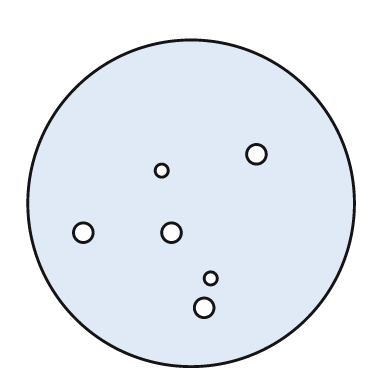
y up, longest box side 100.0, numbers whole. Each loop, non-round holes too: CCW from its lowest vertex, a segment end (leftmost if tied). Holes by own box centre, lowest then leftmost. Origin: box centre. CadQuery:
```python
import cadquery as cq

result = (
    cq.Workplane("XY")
    .moveTo(0.0, 0.0)
    .circle(50.0)
    .moveTo(4.0, -32.0)
    .circle(3.0)
    .moveTo(6.0, -23.0)
    .circle(2.0)
    .moveTo(-33.0, -9.0)
    .circle(3.0)
    .moveTo(-6.0, -9.0)
    .circle(3.0)
    .moveTo(-9.0, 10.0)
    .circle(2.0)
    .moveTo(20.0, 15.0)
    .circle(3.0)
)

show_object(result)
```